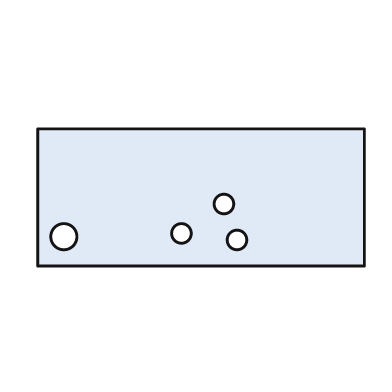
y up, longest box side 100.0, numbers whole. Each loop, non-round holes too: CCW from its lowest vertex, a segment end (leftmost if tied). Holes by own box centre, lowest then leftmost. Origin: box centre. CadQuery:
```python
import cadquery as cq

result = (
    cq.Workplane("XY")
    .moveTo(-50.0, -21.0)
    .lineTo(50.0, -21.0)
    .lineTo(50.0, 21.0)
    .lineTo(-50.0, 21.0)
    .close()
    .moveTo(11.0, -13.0)
    .circle(3.0)
    .moveTo(-42.0, -12.0)
    .circle(4.0)
    .moveTo(-6.0, -11.0)
    .circle(3.0)
    .moveTo(7.0, -2.0)
    .circle(3.0)
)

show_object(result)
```